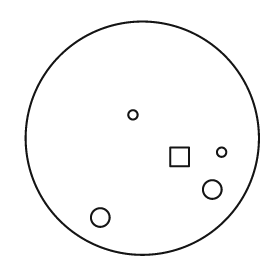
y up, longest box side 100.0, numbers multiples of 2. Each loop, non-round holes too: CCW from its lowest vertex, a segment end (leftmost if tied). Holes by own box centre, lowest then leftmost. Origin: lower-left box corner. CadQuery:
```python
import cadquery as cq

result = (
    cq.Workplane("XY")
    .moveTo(50.0, 50.0)
    .circle(50.0)
    .moveTo(32.0, 16.0)
    .circle(4.0)
    .moveTo(80.0, 28.0)
    .circle(4.0)
    .moveTo(62.0, 38.0)
    .lineTo(70.0, 38.0)
    .lineTo(70.0, 46.0)
    .lineTo(62.0, 46.0)
    .close()
    .moveTo(84.0, 44.0)
    .circle(2.0)
    .moveTo(46.0, 60.0)
    .circle(2.0)
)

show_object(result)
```